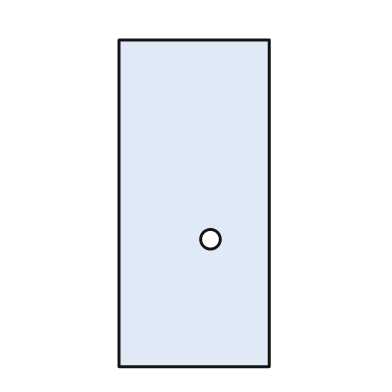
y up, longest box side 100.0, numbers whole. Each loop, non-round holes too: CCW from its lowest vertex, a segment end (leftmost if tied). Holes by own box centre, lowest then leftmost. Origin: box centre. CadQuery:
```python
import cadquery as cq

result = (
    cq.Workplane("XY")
    .moveTo(-23.0, -50.0)
    .lineTo(23.0, -50.0)
    .lineTo(23.0, 50.0)
    .lineTo(-23.0, 50.0)
    .close()
    .moveTo(5.0, -11.0)
    .circle(3.0)
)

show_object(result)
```